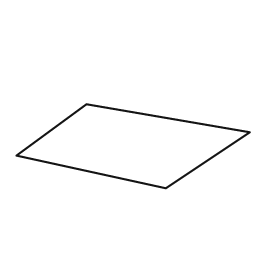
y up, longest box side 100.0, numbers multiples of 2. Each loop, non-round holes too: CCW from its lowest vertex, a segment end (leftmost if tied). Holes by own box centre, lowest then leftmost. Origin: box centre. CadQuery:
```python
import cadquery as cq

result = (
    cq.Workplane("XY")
    .moveTo(14.0, -18.0)
    .lineTo(50.0, 6.0)
    .lineTo(-20.0, 18.0)
    .lineTo(-50.0, -4.0)
    .close()
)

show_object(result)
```